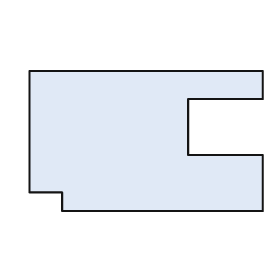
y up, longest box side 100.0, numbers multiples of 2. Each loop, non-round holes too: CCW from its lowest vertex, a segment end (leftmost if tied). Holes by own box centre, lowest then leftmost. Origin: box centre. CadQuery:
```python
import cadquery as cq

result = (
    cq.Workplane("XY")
    .moveTo(-36.0, -30.0)
    .lineTo(50.0, -30.0)
    .lineTo(50.0, -6.0)
    .lineTo(18.0, -6.0)
    .lineTo(18.0, 18.0)
    .lineTo(50.0, 18.0)
    .lineTo(50.0, 30.0)
    .lineTo(-50.0, 30.0)
    .lineTo(-50.0, -22.0)
    .lineTo(-36.0, -22.0)
    .close()
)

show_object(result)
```